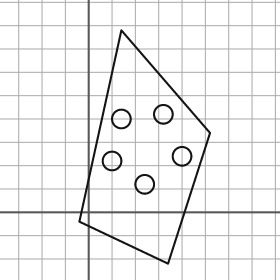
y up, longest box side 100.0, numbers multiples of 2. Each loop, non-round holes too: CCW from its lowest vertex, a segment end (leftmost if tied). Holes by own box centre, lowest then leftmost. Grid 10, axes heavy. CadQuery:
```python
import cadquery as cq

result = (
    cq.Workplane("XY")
    .moveTo(34.0, -22.0)
    .lineTo(52.0, 34.0)
    .lineTo(14.0, 78.0)
    .lineTo(-4.0, -4.0)
    .close()
    .moveTo(24.0, 12.0)
    .circle(4.0)
    .moveTo(10.0, 22.0)
    .circle(4.0)
    .moveTo(40.0, 24.0)
    .circle(4.0)
    .moveTo(14.0, 40.0)
    .circle(4.0)
    .moveTo(32.0, 42.0)
    .circle(4.0)
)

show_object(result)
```